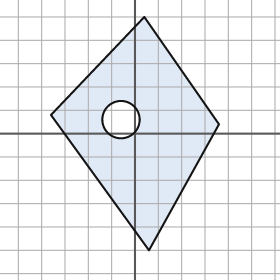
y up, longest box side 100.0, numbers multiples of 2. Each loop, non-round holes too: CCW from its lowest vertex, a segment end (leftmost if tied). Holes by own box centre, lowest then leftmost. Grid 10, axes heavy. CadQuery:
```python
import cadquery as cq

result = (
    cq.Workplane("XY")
    .moveTo(6.0, -50.0)
    .lineTo(36.0, 4.0)
    .lineTo(4.0, 50.0)
    .lineTo(-36.0, 8.0)
    .close()
    .moveTo(-6.0, 6.0)
    .circle(8.0)
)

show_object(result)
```